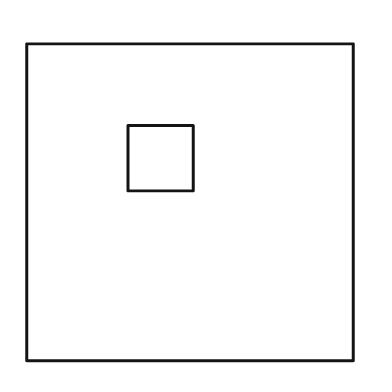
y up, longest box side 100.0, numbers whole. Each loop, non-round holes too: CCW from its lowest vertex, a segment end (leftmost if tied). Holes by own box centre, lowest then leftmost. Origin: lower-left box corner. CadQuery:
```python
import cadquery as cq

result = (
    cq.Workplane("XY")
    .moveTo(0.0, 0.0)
    .lineTo(100.0, 0.0)
    .lineTo(100.0, 97.0)
    .lineTo(0.0, 97.0)
    .close()
    .moveTo(31.0, 52.0)
    .lineTo(51.0, 52.0)
    .lineTo(51.0, 72.0)
    .lineTo(31.0, 72.0)
    .close()
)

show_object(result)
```